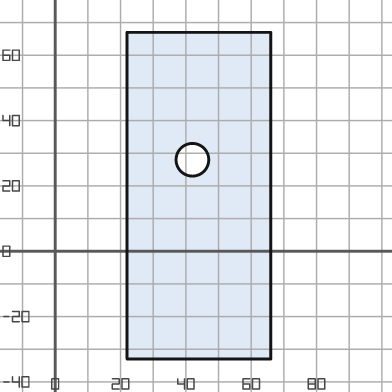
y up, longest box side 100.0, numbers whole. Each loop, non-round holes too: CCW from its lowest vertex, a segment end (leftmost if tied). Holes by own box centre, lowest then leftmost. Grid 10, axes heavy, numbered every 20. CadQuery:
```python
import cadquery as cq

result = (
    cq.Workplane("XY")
    .moveTo(22.0, -33.0)
    .lineTo(66.0, -33.0)
    .lineTo(66.0, 67.0)
    .lineTo(22.0, 67.0)
    .close()
    .moveTo(42.0, 28.0)
    .circle(5.0)
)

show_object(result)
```